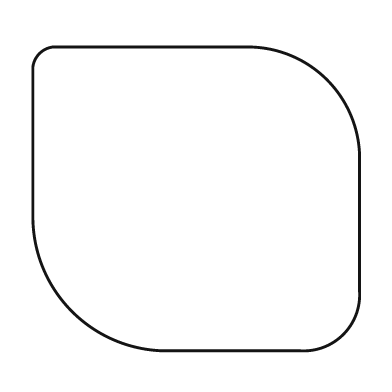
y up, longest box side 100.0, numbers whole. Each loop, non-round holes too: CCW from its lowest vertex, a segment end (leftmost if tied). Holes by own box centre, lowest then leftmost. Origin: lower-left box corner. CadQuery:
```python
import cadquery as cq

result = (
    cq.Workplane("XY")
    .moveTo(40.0, 0.0)
    .lineTo(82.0, 0.0)
    .threePointArc((95.0, 5.0), (100.0, 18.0))
    .lineTo(100.0, 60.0)
    .threePointArc((90.0, 83.0), (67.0, 93.0))
    .lineTo(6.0, 93.0)
    .threePointArc((2.0, 91.0), (0.0, 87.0))
    .lineTo(0.0, 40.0)
    .threePointArc((12.0, 12.0), (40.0, 0.0))
    .close()
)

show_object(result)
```